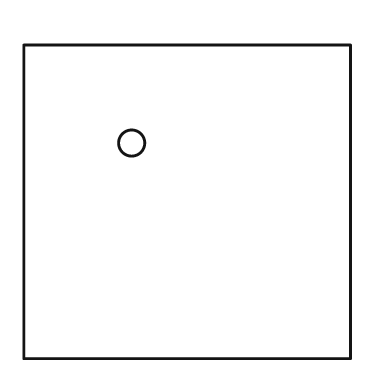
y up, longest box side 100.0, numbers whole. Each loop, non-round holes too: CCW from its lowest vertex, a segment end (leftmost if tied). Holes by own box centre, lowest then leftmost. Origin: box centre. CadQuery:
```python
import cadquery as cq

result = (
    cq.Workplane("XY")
    .moveTo(-50.0, -48.0)
    .lineTo(50.0, -48.0)
    .lineTo(50.0, 48.0)
    .lineTo(-50.0, 48.0)
    .close()
    .moveTo(-17.0, 18.0)
    .circle(4.0)
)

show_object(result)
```